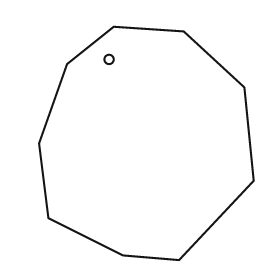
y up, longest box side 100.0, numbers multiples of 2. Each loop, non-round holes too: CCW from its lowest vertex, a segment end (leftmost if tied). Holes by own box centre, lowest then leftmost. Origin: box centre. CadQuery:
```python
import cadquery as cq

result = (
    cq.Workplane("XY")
    .moveTo(14.0, -50.0)
    .lineTo(46.0, -16.0)
    .lineTo(42.0, 24.0)
    .lineTo(16.0, 48.0)
    .lineTo(-14.0, 50.0)
    .lineTo(-34.0, 34.0)
    .lineTo(-46.0, 0.0)
    .lineTo(-42.0, -32.0)
    .lineTo(-10.0, -48.0)
    .close()
    .moveTo(-16.0, 36.0)
    .circle(2.0)
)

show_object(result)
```